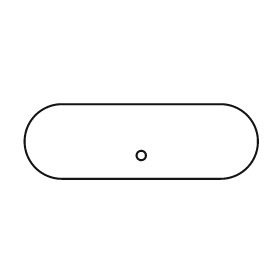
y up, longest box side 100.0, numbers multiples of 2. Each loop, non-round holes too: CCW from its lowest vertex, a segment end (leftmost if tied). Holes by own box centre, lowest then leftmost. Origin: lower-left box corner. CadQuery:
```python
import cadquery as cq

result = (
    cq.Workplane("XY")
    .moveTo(16.0, 0.0)
    .lineTo(84.0, 0.0)
    .threePointArc((100.0, 16.0), (84.0, 32.0))
    .lineTo(16.0, 32.0)
    .threePointArc((0.0, 16.0), (16.0, 0.0))
    .close()
    .moveTo(50.0, 10.0)
    .circle(2.0)
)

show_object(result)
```